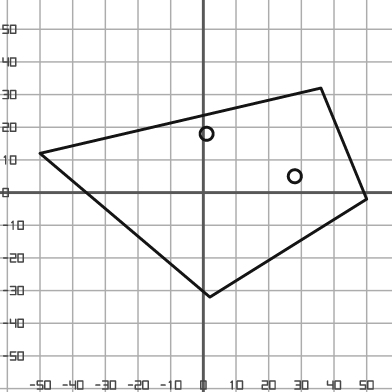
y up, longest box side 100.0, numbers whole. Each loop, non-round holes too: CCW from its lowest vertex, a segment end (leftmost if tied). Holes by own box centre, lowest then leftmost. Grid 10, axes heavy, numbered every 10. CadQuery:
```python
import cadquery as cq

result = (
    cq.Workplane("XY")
    .moveTo(2.0, -32.0)
    .lineTo(50.0, -2.0)
    .lineTo(36.0, 32.0)
    .lineTo(-50.0, 12.0)
    .close()
    .moveTo(28.0, 5.0)
    .circle(2.0)
    .moveTo(1.0, 18.0)
    .circle(2.0)
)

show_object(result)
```